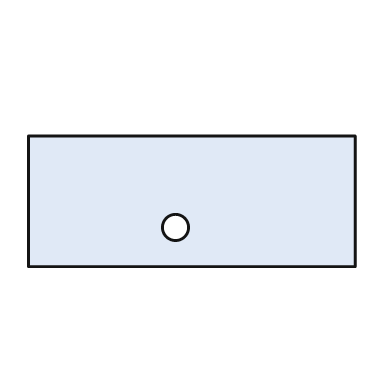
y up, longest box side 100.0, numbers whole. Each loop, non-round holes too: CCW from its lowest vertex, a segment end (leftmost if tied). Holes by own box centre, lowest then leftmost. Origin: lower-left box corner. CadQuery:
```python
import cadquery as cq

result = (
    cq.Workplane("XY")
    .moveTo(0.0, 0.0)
    .lineTo(100.0, 0.0)
    .lineTo(100.0, 40.0)
    .lineTo(0.0, 40.0)
    .close()
    .moveTo(45.0, 12.0)
    .circle(4.0)
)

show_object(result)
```